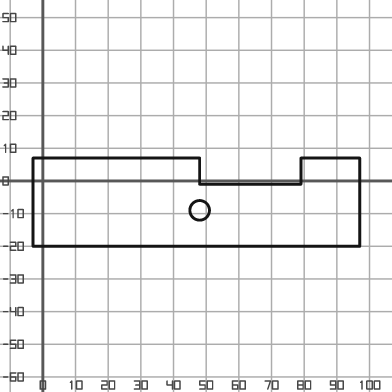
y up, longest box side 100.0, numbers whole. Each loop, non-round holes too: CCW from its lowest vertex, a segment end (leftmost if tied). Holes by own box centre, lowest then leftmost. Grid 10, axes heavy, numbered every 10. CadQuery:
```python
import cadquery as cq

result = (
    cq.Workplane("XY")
    .moveTo(-3.0, -20.0)
    .lineTo(97.0, -20.0)
    .lineTo(97.0, 7.0)
    .lineTo(79.0, 7.0)
    .lineTo(79.0, -1.0)
    .lineTo(48.0, -1.0)
    .lineTo(48.0, 7.0)
    .lineTo(-3.0, 7.0)
    .close()
    .moveTo(48.0, -9.0)
    .circle(3.0)
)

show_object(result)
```